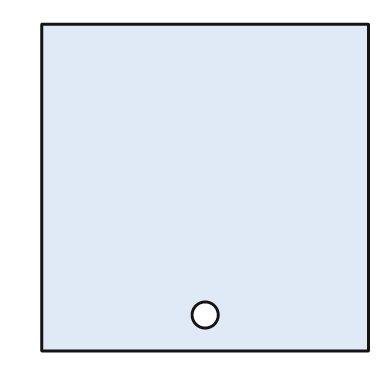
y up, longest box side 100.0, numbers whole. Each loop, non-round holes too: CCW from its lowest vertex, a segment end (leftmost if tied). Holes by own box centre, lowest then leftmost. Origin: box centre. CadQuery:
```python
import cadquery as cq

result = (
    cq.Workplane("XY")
    .moveTo(-50.0, -50.0)
    .lineTo(50.0, -50.0)
    .lineTo(50.0, 50.0)
    .lineTo(-50.0, 50.0)
    .close()
    .moveTo(0.0, -39.0)
    .circle(4.0)
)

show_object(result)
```